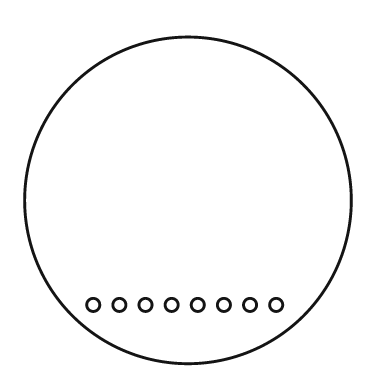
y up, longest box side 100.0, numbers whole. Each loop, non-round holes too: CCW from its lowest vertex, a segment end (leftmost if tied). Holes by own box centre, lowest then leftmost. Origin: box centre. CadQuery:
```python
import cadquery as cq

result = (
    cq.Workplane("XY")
    .moveTo(0.0, 0.0)
    .circle(50.0)
    .moveTo(-29.0, -32.0)
    .circle(2.0)
    .moveTo(-21.0, -32.0)
    .circle(2.0)
    .moveTo(-13.0, -32.0)
    .circle(2.0)
    .moveTo(-5.0, -32.0)
    .circle(2.0)
    .moveTo(3.0, -32.0)
    .circle(2.0)
    .moveTo(11.0, -32.0)
    .circle(2.0)
    .moveTo(19.0, -32.0)
    .circle(2.0)
    .moveTo(27.0, -32.0)
    .circle(2.0)
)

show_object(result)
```